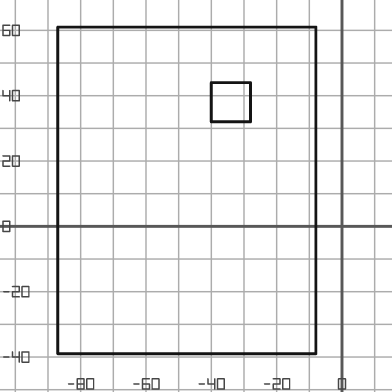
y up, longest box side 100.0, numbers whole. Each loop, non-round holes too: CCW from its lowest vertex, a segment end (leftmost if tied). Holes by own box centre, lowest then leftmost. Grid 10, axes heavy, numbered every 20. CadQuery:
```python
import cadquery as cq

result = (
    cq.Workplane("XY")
    .moveTo(-87.0, -39.0)
    .lineTo(-8.0, -39.0)
    .lineTo(-8.0, 61.0)
    .lineTo(-87.0, 61.0)
    .close()
    .moveTo(-40.0, 32.0)
    .lineTo(-28.0, 32.0)
    .lineTo(-28.0, 44.0)
    .lineTo(-40.0, 44.0)
    .close()
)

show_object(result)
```